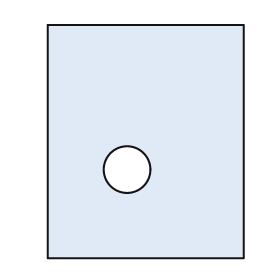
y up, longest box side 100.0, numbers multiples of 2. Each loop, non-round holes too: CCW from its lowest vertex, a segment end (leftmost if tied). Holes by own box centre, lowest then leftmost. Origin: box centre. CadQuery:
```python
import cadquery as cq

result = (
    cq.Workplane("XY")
    .moveTo(-42.0, -50.0)
    .lineTo(42.0, -50.0)
    .lineTo(42.0, 50.0)
    .lineTo(-42.0, 50.0)
    .close()
    .moveTo(-8.0, -12.0)
    .circle(10.0)
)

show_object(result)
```